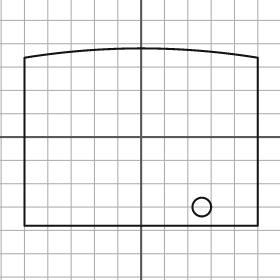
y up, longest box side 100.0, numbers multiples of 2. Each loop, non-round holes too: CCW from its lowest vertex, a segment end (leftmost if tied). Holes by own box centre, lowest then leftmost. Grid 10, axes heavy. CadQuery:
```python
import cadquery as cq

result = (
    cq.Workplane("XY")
    .moveTo(-50.0, -38.0)
    .lineTo(50.0, -38.0)
    .lineTo(50.0, 34.0)
    .threePointArc((0.0, 38.0), (-50.0, 34.0))
    .close()
    .moveTo(26.0, -30.0)
    .circle(4.0)
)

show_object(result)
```